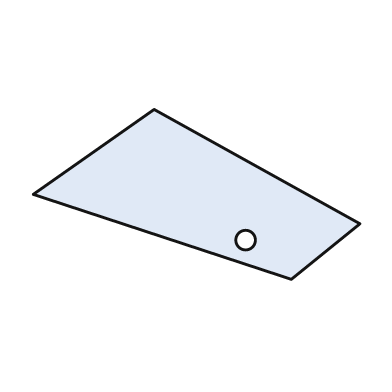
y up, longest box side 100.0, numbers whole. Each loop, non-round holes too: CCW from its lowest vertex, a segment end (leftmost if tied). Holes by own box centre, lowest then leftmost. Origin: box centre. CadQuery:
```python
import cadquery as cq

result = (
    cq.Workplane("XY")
    .moveTo(29.0, -26.0)
    .lineTo(50.0, -9.0)
    .lineTo(-13.0, 26.0)
    .lineTo(-50.0, 0.0)
    .close()
    .moveTo(15.0, -14.0)
    .circle(3.0)
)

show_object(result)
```